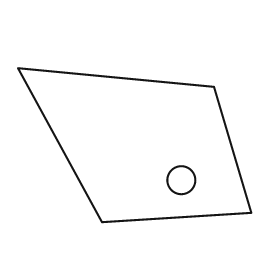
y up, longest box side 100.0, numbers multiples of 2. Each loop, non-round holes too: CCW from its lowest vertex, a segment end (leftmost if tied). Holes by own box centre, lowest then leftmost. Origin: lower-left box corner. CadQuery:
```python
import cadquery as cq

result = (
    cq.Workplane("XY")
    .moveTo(36.0, 0.0)
    .lineTo(100.0, 4.0)
    .lineTo(84.0, 58.0)
    .lineTo(0.0, 66.0)
    .close()
    .moveTo(70.0, 18.0)
    .circle(6.0)
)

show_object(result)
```